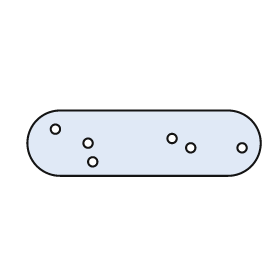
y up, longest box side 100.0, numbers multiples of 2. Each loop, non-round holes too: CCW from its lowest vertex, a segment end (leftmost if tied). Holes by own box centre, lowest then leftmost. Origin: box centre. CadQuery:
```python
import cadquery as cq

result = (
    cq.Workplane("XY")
    .moveTo(-36.0, -14.0)
    .lineTo(36.0, -14.0)
    .threePointArc((50.0, 0.0), (36.0, 14.0))
    .lineTo(-36.0, 14.0)
    .threePointArc((-50.0, 0.0), (-36.0, -14.0))
    .close()
    .moveTo(-22.0, -8.0)
    .circle(2.0)
    .moveTo(20.0, -2.0)
    .circle(2.0)
    .moveTo(42.0, -2.0)
    .circle(2.0)
    .moveTo(-24.0, 0.0)
    .circle(2.0)
    .moveTo(12.0, 2.0)
    .circle(2.0)
    .moveTo(-38.0, 6.0)
    .circle(2.0)
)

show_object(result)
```